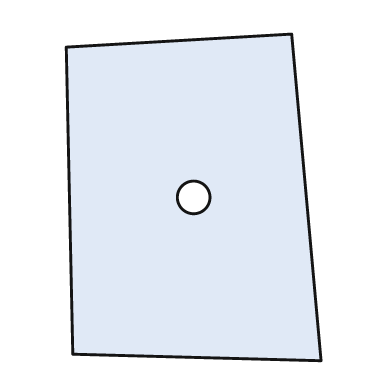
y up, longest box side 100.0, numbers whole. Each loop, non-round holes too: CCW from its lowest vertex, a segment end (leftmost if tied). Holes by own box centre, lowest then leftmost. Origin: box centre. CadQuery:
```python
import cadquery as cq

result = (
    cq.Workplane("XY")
    .moveTo(39.0, -50.0)
    .lineTo(30.0, 50.0)
    .lineTo(-39.0, 46.0)
    .lineTo(-37.0, -48.0)
    .close()
    .moveTo(0.0, 0.0)
    .circle(5.0)
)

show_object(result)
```